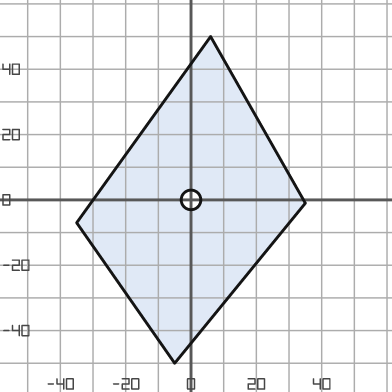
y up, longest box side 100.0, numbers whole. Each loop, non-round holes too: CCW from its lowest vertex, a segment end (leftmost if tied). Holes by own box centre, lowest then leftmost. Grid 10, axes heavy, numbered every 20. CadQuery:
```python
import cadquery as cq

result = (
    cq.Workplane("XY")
    .moveTo(-5.0, -50.0)
    .lineTo(35.0, -1.0)
    .lineTo(6.0, 50.0)
    .lineTo(-35.0, -7.0)
    .close()
    .moveTo(0.0, 0.0)
    .circle(3.0)
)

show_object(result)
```